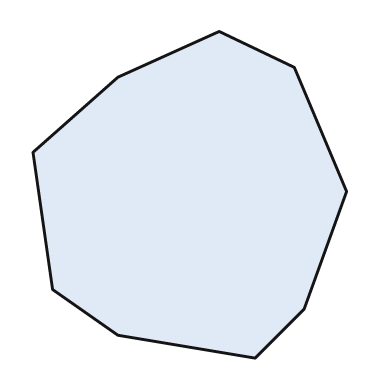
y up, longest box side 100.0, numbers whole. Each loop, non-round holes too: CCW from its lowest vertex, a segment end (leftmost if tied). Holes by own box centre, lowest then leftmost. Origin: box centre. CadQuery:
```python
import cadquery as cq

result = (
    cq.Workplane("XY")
    .moveTo(20.0, -50.0)
    .lineTo(35.0, -35.0)
    .lineTo(48.0, 1.0)
    .lineTo(32.0, 39.0)
    .lineTo(9.0, 50.0)
    .lineTo(-22.0, 36.0)
    .lineTo(-48.0, 13.0)
    .lineTo(-42.0, -29.0)
    .lineTo(-22.0, -43.0)
    .close()
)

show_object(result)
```